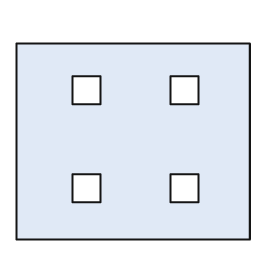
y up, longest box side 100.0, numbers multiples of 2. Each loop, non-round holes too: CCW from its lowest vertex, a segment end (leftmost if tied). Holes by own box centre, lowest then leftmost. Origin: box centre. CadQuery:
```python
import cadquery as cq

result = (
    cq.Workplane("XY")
    .moveTo(-50.0, -42.0)
    .lineTo(50.0, -42.0)
    .lineTo(50.0, 42.0)
    .lineTo(-50.0, 42.0)
    .close()
    .moveTo(-26.0, -26.0)
    .lineTo(-14.0, -26.0)
    .lineTo(-14.0, -14.0)
    .lineTo(-26.0, -14.0)
    .close()
    .moveTo(16.0, -26.0)
    .lineTo(28.0, -26.0)
    .lineTo(28.0, -14.0)
    .lineTo(16.0, -14.0)
    .close()
    .moveTo(-26.0, 16.0)
    .lineTo(-14.0, 16.0)
    .lineTo(-14.0, 28.0)
    .lineTo(-26.0, 28.0)
    .close()
    .moveTo(16.0, 16.0)
    .lineTo(28.0, 16.0)
    .lineTo(28.0, 28.0)
    .lineTo(16.0, 28.0)
    .close()
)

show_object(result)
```